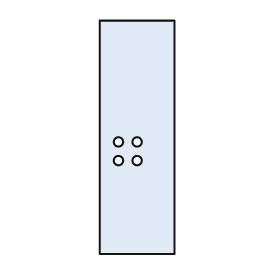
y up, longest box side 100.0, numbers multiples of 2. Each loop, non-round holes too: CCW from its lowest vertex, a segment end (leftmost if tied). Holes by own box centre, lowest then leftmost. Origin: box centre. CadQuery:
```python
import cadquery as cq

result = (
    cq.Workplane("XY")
    .moveTo(-16.0, -50.0)
    .lineTo(16.0, -50.0)
    .lineTo(16.0, 50.0)
    .lineTo(-16.0, 50.0)
    .close()
    .moveTo(-8.0, -10.0)
    .circle(2.0)
    .moveTo(0.0, -10.0)
    .circle(2.0)
    .moveTo(-8.0, -2.0)
    .circle(2.0)
    .moveTo(0.0, -2.0)
    .circle(2.0)
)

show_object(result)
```